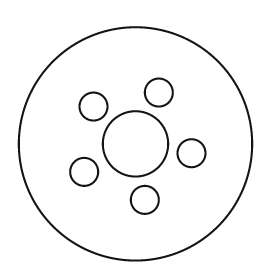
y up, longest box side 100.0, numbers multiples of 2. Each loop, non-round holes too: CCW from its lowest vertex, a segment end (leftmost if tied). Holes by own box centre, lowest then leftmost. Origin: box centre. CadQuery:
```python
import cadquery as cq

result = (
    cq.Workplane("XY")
    .moveTo(0.0, 0.0)
    .circle(50.0)
    .moveTo(4.0, -24.0)
    .circle(6.0)
    .moveTo(-22.0, -12.0)
    .circle(6.0)
    .moveTo(24.0, -4.0)
    .circle(6.0)
    .moveTo(0.0, 0.0)
    .circle(14.0)
    .moveTo(-18.0, 16.0)
    .circle(6.0)
    .moveTo(10.0, 22.0)
    .circle(6.0)
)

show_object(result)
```